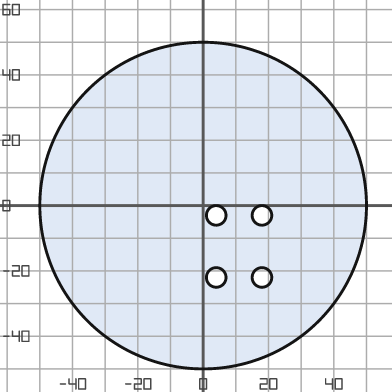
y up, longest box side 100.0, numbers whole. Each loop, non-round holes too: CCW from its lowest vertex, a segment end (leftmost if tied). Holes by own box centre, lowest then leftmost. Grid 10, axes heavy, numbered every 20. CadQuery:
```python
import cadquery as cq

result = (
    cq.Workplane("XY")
    .moveTo(0.0, 0.0)
    .circle(50.0)
    .moveTo(4.0, -22.0)
    .circle(3.0)
    .moveTo(18.0, -22.0)
    .circle(3.0)
    .moveTo(4.0, -3.0)
    .circle(3.0)
    .moveTo(18.0, -3.0)
    .circle(3.0)
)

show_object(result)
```